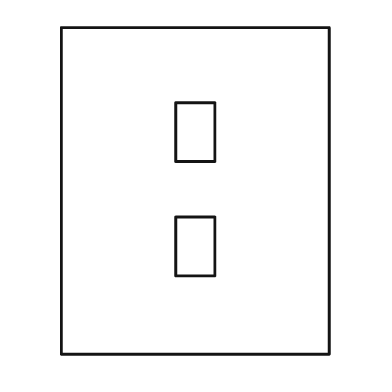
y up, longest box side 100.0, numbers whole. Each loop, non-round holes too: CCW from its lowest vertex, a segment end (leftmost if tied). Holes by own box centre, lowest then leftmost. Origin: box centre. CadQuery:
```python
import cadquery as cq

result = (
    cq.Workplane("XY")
    .moveTo(-41.0, -50.0)
    .lineTo(41.0, -50.0)
    .lineTo(41.0, 50.0)
    .lineTo(-41.0, 50.0)
    .close()
    .moveTo(-6.0, -26.0)
    .lineTo(6.0, -26.0)
    .lineTo(6.0, -8.0)
    .lineTo(-6.0, -8.0)
    .close()
    .moveTo(-6.0, 9.0)
    .lineTo(6.0, 9.0)
    .lineTo(6.0, 27.0)
    .lineTo(-6.0, 27.0)
    .close()
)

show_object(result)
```